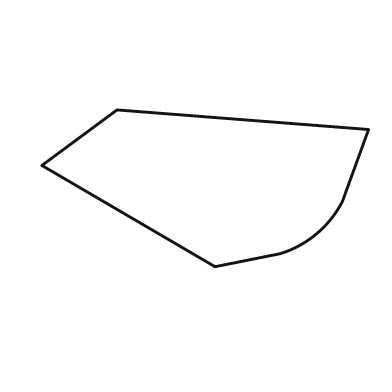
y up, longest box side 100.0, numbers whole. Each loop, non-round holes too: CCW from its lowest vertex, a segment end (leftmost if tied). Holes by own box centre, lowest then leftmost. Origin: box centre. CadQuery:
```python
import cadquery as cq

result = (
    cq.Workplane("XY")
    .moveTo(3.0, -24.0)
    .lineTo(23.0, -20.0)
    .threePointArc((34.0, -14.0), (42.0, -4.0))
    .lineTo(50.0, 18.0)
    .lineTo(-27.0, 24.0)
    .lineTo(-50.0, 7.0)
    .close()
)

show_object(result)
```